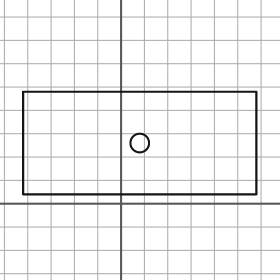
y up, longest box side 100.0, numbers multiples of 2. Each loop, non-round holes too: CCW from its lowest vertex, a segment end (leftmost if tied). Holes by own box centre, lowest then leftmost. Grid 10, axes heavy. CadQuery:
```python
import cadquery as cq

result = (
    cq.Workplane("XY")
    .moveTo(-42.0, 4.0)
    .lineTo(58.0, 4.0)
    .lineTo(58.0, 48.0)
    .lineTo(-42.0, 48.0)
    .close()
    .moveTo(8.0, 26.0)
    .circle(4.0)
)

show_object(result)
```